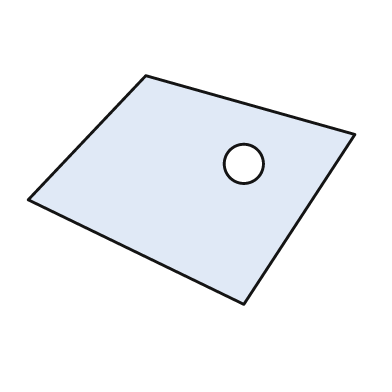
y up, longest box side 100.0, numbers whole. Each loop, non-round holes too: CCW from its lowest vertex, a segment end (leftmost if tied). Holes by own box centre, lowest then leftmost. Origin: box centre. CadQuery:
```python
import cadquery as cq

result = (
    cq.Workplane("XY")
    .moveTo(16.0, -35.0)
    .lineTo(50.0, 17.0)
    .lineTo(-14.0, 35.0)
    .lineTo(-50.0, -3.0)
    .close()
    .moveTo(16.0, 8.0)
    .circle(6.0)
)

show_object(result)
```